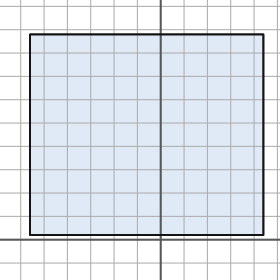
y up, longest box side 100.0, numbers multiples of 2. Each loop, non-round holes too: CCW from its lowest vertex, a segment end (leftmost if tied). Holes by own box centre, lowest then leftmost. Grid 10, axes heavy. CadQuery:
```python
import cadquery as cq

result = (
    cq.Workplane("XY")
    .moveTo(-56.0, 2.0)
    .lineTo(44.0, 2.0)
    .lineTo(44.0, 88.0)
    .lineTo(-56.0, 88.0)
    .close()
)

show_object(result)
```